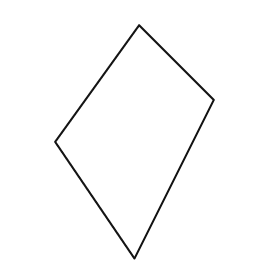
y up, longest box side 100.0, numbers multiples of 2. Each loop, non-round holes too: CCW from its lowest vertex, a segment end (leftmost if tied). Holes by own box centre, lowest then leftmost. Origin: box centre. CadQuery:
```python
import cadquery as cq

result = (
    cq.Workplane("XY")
    .moveTo(0.0, -50.0)
    .lineTo(34.0, 18.0)
    .lineTo(2.0, 50.0)
    .lineTo(-34.0, 0.0)
    .close()
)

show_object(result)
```